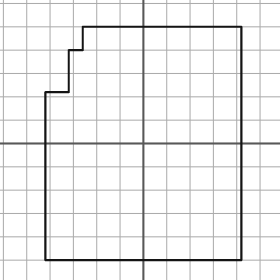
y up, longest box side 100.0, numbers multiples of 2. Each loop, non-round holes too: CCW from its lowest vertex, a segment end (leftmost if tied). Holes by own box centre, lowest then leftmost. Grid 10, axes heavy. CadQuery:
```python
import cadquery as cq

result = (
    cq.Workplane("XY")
    .moveTo(-42.0, -50.0)
    .lineTo(42.0, -50.0)
    .lineTo(42.0, 50.0)
    .lineTo(-26.0, 50.0)
    .lineTo(-26.0, 40.0)
    .lineTo(-32.0, 40.0)
    .lineTo(-32.0, 22.0)
    .lineTo(-42.0, 22.0)
    .close()
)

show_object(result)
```